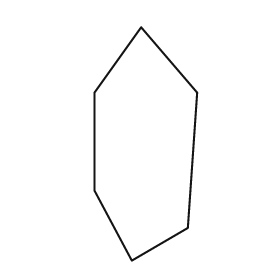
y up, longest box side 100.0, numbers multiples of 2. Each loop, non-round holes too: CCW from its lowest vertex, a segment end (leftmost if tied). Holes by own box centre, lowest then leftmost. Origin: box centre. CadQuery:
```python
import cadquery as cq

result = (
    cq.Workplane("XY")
    .moveTo(-6.0, -50.0)
    .lineTo(18.0, -36.0)
    .lineTo(22.0, 22.0)
    .lineTo(-2.0, 50.0)
    .lineTo(-22.0, 22.0)
    .lineTo(-22.0, -20.0)
    .close()
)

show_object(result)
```